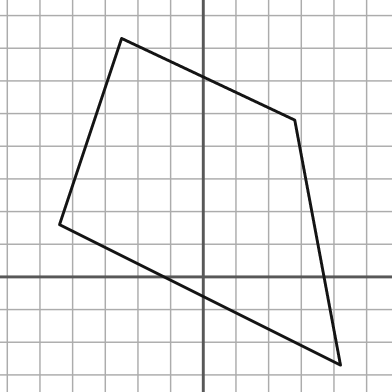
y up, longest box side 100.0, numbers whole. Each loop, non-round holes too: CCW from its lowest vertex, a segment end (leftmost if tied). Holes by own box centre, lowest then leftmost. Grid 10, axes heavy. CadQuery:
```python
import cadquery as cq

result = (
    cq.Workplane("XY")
    .moveTo(42.0, -27.0)
    .lineTo(28.0, 48.0)
    .lineTo(-25.0, 73.0)
    .lineTo(-44.0, 16.0)
    .close()
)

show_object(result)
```